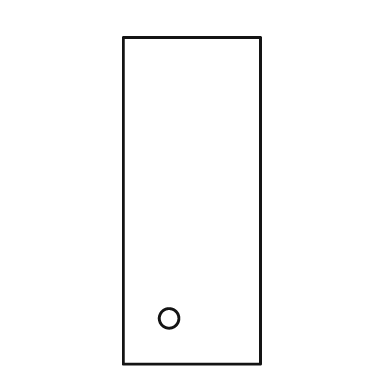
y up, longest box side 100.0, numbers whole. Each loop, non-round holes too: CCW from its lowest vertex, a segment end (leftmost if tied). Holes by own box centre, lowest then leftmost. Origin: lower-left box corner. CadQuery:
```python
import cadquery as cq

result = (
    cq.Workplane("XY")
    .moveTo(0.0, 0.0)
    .lineTo(42.0, 0.0)
    .lineTo(42.0, 100.0)
    .lineTo(0.0, 100.0)
    .close()
    .moveTo(14.0, 14.0)
    .circle(3.0)
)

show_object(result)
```